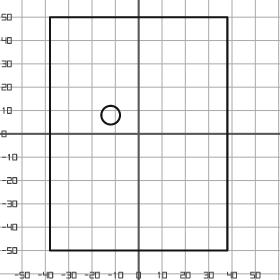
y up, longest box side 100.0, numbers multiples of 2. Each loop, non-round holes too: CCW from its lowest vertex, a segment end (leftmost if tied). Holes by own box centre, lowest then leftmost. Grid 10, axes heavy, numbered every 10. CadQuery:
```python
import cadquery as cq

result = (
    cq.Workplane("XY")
    .moveTo(-38.0, -50.0)
    .lineTo(38.0, -50.0)
    .lineTo(38.0, 50.0)
    .lineTo(-38.0, 50.0)
    .close()
    .moveTo(-12.0, 8.0)
    .circle(4.0)
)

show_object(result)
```